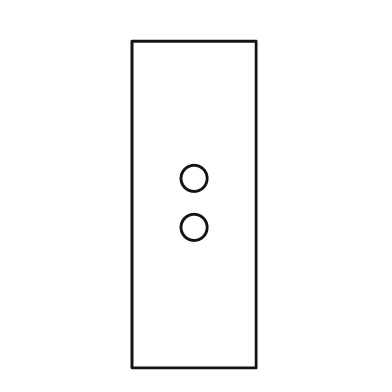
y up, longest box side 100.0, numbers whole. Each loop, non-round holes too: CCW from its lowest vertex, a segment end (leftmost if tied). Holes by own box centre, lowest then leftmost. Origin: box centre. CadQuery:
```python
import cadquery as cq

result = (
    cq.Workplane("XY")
    .moveTo(-19.0, -50.0)
    .lineTo(19.0, -50.0)
    .lineTo(19.0, 50.0)
    .lineTo(-19.0, 50.0)
    .close()
    .moveTo(0.0, -7.0)
    .circle(4.0)
    .moveTo(0.0, 8.0)
    .circle(4.0)
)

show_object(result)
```